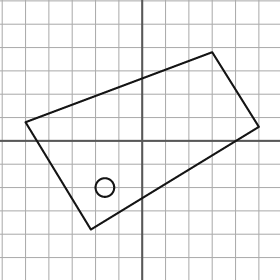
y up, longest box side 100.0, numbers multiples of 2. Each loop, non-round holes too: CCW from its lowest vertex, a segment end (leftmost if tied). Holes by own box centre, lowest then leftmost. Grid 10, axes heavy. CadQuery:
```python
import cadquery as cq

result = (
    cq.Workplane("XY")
    .moveTo(-22.0, -38.0)
    .lineTo(50.0, 6.0)
    .lineTo(30.0, 38.0)
    .lineTo(-50.0, 8.0)
    .close()
    .moveTo(-16.0, -20.0)
    .circle(4.0)
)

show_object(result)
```